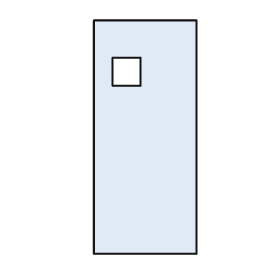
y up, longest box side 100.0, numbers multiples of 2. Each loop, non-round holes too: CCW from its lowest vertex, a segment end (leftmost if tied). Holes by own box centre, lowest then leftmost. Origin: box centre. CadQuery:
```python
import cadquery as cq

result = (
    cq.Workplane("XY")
    .moveTo(-22.0, -50.0)
    .lineTo(22.0, -50.0)
    .lineTo(22.0, 50.0)
    .lineTo(-22.0, 50.0)
    .close()
    .moveTo(-14.0, 22.0)
    .lineTo(-2.0, 22.0)
    .lineTo(-2.0, 34.0)
    .lineTo(-14.0, 34.0)
    .close()
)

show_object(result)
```